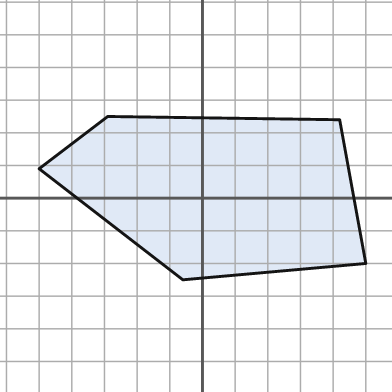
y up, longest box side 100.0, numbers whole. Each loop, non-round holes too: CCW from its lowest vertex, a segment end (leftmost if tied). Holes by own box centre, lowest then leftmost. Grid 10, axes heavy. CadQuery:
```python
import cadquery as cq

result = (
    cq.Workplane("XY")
    .moveTo(-6.0, -25.0)
    .lineTo(50.0, -20.0)
    .lineTo(42.0, 24.0)
    .lineTo(-29.0, 25.0)
    .lineTo(-50.0, 9.0)
    .close()
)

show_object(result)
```